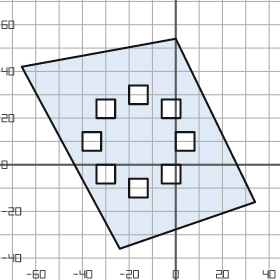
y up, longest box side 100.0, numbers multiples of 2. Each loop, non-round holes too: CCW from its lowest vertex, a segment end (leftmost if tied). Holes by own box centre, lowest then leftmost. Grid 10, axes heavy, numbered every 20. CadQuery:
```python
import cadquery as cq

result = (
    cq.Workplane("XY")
    .moveTo(-24.0, -36.0)
    .lineTo(34.0, -16.0)
    .lineTo(0.0, 54.0)
    .lineTo(-66.0, 42.0)
    .close()
    .moveTo(-20.0, -14.0)
    .lineTo(-12.0, -14.0)
    .lineTo(-12.0, -6.0)
    .lineTo(-20.0, -6.0)
    .close()
    .moveTo(-34.0, -8.0)
    .lineTo(-26.0, -8.0)
    .lineTo(-26.0, 0.0)
    .lineTo(-34.0, 0.0)
    .close()
    .moveTo(-6.0, -8.0)
    .lineTo(2.0, -8.0)
    .lineTo(2.0, 0.0)
    .lineTo(-6.0, 0.0)
    .close()
    .moveTo(-40.0, 6.0)
    .lineTo(-32.0, 6.0)
    .lineTo(-32.0, 14.0)
    .lineTo(-40.0, 14.0)
    .close()
    .moveTo(0.0, 6.0)
    .lineTo(8.0, 6.0)
    .lineTo(8.0, 14.0)
    .lineTo(0.0, 14.0)
    .close()
    .moveTo(-34.0, 20.0)
    .lineTo(-26.0, 20.0)
    .lineTo(-26.0, 28.0)
    .lineTo(-34.0, 28.0)
    .close()
    .moveTo(-6.0, 20.0)
    .lineTo(2.0, 20.0)
    .lineTo(2.0, 28.0)
    .lineTo(-6.0, 28.0)
    .close()
    .moveTo(-20.0, 26.0)
    .lineTo(-12.0, 26.0)
    .lineTo(-12.0, 34.0)
    .lineTo(-20.0, 34.0)
    .close()
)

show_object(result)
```